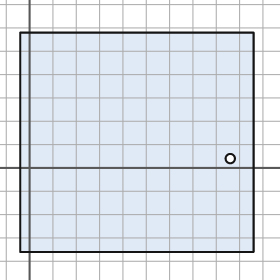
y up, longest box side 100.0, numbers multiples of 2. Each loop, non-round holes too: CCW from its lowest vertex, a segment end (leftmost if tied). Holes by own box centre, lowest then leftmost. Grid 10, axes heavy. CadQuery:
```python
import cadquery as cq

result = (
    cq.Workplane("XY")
    .moveTo(-4.0, -36.0)
    .lineTo(96.0, -36.0)
    .lineTo(96.0, 58.0)
    .lineTo(-4.0, 58.0)
    .close()
    .moveTo(86.0, 4.0)
    .circle(2.0)
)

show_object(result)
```